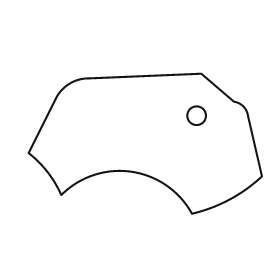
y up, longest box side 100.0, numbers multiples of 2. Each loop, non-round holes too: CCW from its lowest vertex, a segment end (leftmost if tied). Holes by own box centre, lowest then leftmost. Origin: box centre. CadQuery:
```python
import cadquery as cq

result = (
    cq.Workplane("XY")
    .moveTo(20.0, -30.0)
    .threePointArc((36.0, -24.0), (50.0, -14.0))
    .lineTo(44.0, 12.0)
    .threePointArc((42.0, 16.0), (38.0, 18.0))
    .lineTo(24.0, 30.0)
    .lineTo(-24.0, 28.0)
    .threePointArc((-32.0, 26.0), (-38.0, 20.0))
    .lineTo(-50.0, -4.0)
    .threePointArc((-42.0, -12.0), (-36.0, -22.0))
    .threePointArc((-6.0, -12.0), (20.0, -30.0))
    .close()
    .moveTo(22.0, 12.0)
    .circle(4.0)
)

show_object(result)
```